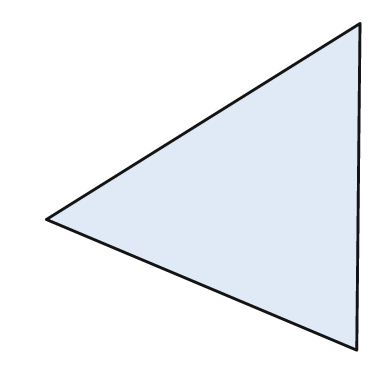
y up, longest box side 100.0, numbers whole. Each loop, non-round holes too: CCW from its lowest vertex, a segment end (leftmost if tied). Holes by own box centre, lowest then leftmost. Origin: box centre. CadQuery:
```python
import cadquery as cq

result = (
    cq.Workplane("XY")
    .moveTo(47.0, -50.0)
    .lineTo(48.0, 50.0)
    .lineTo(-48.0, -10.0)
    .close()
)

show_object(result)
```